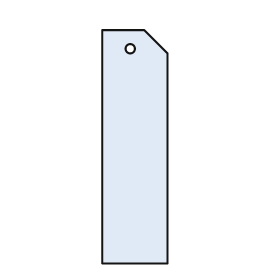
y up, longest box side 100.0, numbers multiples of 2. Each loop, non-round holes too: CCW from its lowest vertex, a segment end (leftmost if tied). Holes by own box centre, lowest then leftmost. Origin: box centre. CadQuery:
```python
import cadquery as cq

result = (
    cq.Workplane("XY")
    .moveTo(-14.0, -50.0)
    .lineTo(14.0, -50.0)
    .lineTo(14.0, 40.0)
    .lineTo(4.0, 50.0)
    .lineTo(-14.0, 50.0)
    .close()
    .moveTo(-2.0, 42.0)
    .circle(2.0)
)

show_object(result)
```